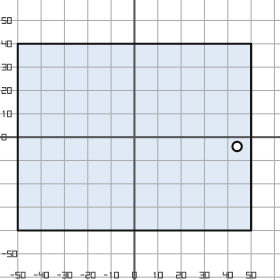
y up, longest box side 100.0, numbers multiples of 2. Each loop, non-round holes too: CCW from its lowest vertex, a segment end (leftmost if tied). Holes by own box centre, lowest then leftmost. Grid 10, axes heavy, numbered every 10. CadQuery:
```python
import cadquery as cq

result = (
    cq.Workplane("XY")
    .moveTo(-50.0, -40.0)
    .lineTo(50.0, -40.0)
    .lineTo(50.0, 40.0)
    .lineTo(-50.0, 40.0)
    .close()
    .moveTo(44.0, -4.0)
    .circle(2.0)
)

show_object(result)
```